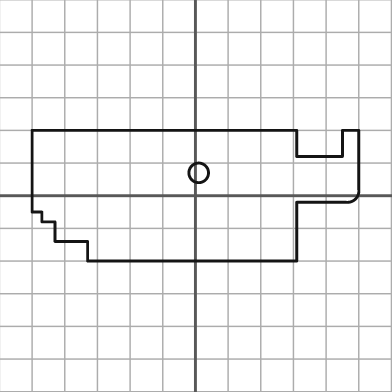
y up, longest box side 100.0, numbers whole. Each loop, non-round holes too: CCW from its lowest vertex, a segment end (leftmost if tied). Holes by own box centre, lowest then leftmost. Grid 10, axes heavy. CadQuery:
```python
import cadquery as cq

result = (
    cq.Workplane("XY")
    .moveTo(-33.0, -20.0)
    .lineTo(31.0, -20.0)
    .lineTo(31.0, -2.0)
    .lineTo(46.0, -2.0)
    .threePointArc((49.0, -1.0), (50.0, 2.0))
    .lineTo(50.0, 20.0)
    .lineTo(45.0, 20.0)
    .lineTo(45.0, 12.0)
    .lineTo(31.0, 12.0)
    .lineTo(31.0, 20.0)
    .lineTo(-50.0, 20.0)
    .lineTo(-50.0, -5.0)
    .lineTo(-47.0, -5.0)
    .lineTo(-47.0, -8.0)
    .lineTo(-43.0, -8.0)
    .lineTo(-43.0, -14.0)
    .lineTo(-33.0, -14.0)
    .close()
    .moveTo(1.0, 7.0)
    .circle(3.0)
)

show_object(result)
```